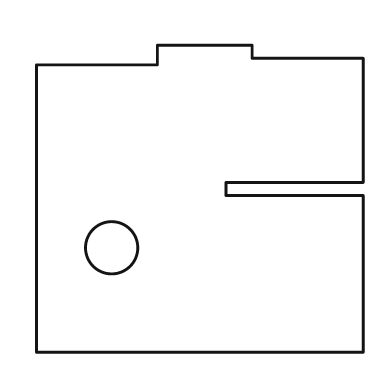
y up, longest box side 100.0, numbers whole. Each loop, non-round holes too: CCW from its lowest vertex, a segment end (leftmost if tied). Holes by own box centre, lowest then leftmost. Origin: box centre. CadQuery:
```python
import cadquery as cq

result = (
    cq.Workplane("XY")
    .moveTo(-50.0, -47.0)
    .lineTo(50.0, -47.0)
    .lineTo(50.0, 1.0)
    .lineTo(8.0, 1.0)
    .lineTo(8.0, 5.0)
    .lineTo(50.0, 5.0)
    .lineTo(50.0, 43.0)
    .lineTo(16.0, 43.0)
    .lineTo(16.0, 47.0)
    .lineTo(-13.0, 47.0)
    .lineTo(-13.0, 41.0)
    .lineTo(-50.0, 41.0)
    .close()
    .moveTo(-27.0, -15.0)
    .circle(8.0)
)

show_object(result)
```